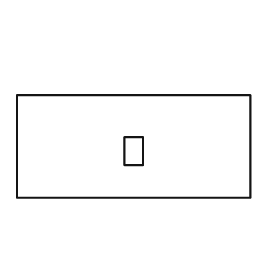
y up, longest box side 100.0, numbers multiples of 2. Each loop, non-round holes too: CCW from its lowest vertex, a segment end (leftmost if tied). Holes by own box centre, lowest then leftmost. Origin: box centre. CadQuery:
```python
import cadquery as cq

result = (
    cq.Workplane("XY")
    .moveTo(-50.0, -22.0)
    .lineTo(50.0, -22.0)
    .lineTo(50.0, 22.0)
    .lineTo(-50.0, 22.0)
    .close()
    .moveTo(-4.0, -8.0)
    .lineTo(4.0, -8.0)
    .lineTo(4.0, 4.0)
    .lineTo(-4.0, 4.0)
    .close()
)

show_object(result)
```